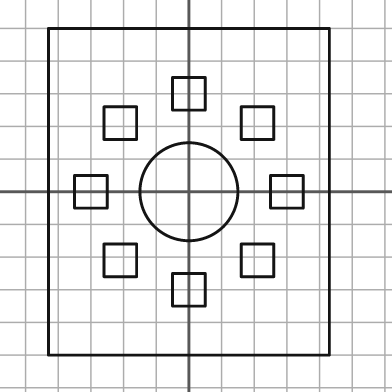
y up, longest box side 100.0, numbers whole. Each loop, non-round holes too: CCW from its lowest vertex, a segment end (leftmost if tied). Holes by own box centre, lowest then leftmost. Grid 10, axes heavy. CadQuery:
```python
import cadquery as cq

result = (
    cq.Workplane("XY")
    .moveTo(-43.0, -50.0)
    .lineTo(43.0, -50.0)
    .lineTo(43.0, 50.0)
    .lineTo(-43.0, 50.0)
    .close()
    .moveTo(-5.0, -35.0)
    .lineTo(5.0, -35.0)
    .lineTo(5.0, -25.0)
    .lineTo(-5.0, -25.0)
    .close()
    .moveTo(-26.0, -26.0)
    .lineTo(-16.0, -26.0)
    .lineTo(-16.0, -16.0)
    .lineTo(-26.0, -16.0)
    .close()
    .moveTo(16.0, -26.0)
    .lineTo(26.0, -26.0)
    .lineTo(26.0, -16.0)
    .lineTo(16.0, -16.0)
    .close()
    .moveTo(-35.0, -5.0)
    .lineTo(-25.0, -5.0)
    .lineTo(-25.0, 5.0)
    .lineTo(-35.0, 5.0)
    .close()
    .moveTo(0.0, 0.0)
    .circle(15.0)
    .moveTo(25.0, -5.0)
    .lineTo(35.0, -5.0)
    .lineTo(35.0, 5.0)
    .lineTo(25.0, 5.0)
    .close()
    .moveTo(-26.0, 16.0)
    .lineTo(-16.0, 16.0)
    .lineTo(-16.0, 26.0)
    .lineTo(-26.0, 26.0)
    .close()
    .moveTo(16.0, 16.0)
    .lineTo(26.0, 16.0)
    .lineTo(26.0, 26.0)
    .lineTo(16.0, 26.0)
    .close()
    .moveTo(-5.0, 25.0)
    .lineTo(5.0, 25.0)
    .lineTo(5.0, 35.0)
    .lineTo(-5.0, 35.0)
    .close()
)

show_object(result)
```